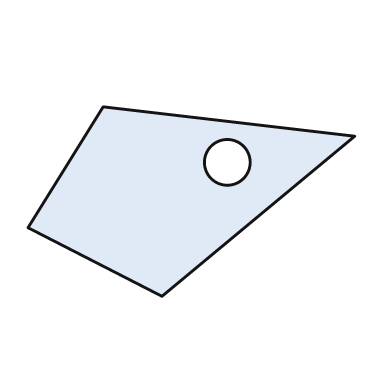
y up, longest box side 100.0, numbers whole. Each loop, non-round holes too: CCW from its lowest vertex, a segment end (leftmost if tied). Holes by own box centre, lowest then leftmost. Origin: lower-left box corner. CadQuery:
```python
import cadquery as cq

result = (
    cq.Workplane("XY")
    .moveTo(41.0, 0.0)
    .lineTo(100.0, 49.0)
    .lineTo(23.0, 58.0)
    .lineTo(0.0, 21.0)
    .close()
    .moveTo(61.0, 41.0)
    .circle(7.0)
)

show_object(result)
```